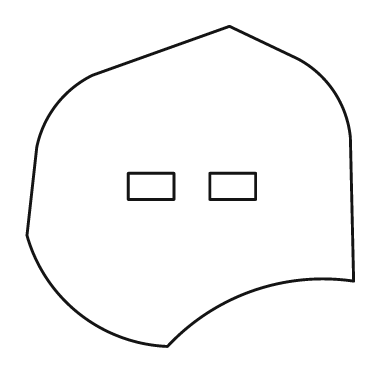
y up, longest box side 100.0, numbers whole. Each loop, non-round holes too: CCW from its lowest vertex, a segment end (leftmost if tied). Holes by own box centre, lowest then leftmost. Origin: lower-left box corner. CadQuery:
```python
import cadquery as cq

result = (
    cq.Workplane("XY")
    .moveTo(43.0, 0.0)
    .threePointArc((69.0, 17.0), (100.0, 20.0))
    .lineTo(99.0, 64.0)
    .threePointArc((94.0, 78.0), (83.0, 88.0))
    .lineTo(62.0, 98.0)
    .lineTo(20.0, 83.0)
    .threePointArc((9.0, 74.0), (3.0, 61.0))
    .lineTo(0.0, 34.0)
    .threePointArc((16.0, 10.0), (43.0, 0.0))
    .close()
    .moveTo(31.0, 45.0)
    .lineTo(45.0, 45.0)
    .lineTo(45.0, 53.0)
    .lineTo(31.0, 53.0)
    .close()
    .moveTo(56.0, 45.0)
    .lineTo(70.0, 45.0)
    .lineTo(70.0, 53.0)
    .lineTo(56.0, 53.0)
    .close()
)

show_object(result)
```